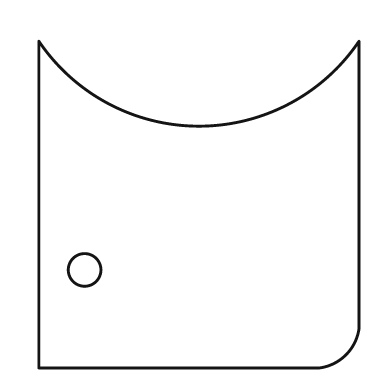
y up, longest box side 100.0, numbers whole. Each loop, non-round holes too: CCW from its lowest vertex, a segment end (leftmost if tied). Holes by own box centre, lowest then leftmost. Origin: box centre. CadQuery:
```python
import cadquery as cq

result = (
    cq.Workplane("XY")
    .moveTo(-49.0, -50.0)
    .lineTo(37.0, -50.0)
    .threePointArc((45.0, -46.0), (49.0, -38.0))
    .lineTo(49.0, 50.0)
    .threePointArc((0.0, 24.0), (-49.0, 50.0))
    .close()
    .moveTo(-35.0, -20.0)
    .circle(5.0)
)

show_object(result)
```